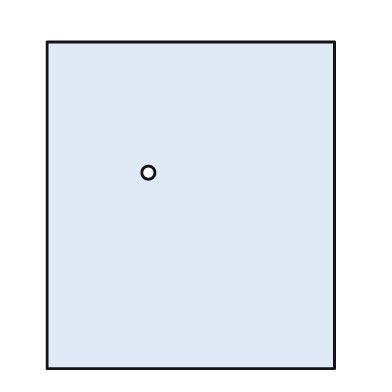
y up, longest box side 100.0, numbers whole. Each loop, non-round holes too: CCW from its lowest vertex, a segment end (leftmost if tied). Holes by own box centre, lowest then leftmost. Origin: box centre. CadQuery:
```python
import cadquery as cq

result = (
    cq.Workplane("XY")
    .moveTo(-44.0, -50.0)
    .lineTo(44.0, -50.0)
    .lineTo(44.0, 50.0)
    .lineTo(-44.0, 50.0)
    .close()
    .moveTo(-13.0, 10.0)
    .circle(2.0)
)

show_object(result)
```